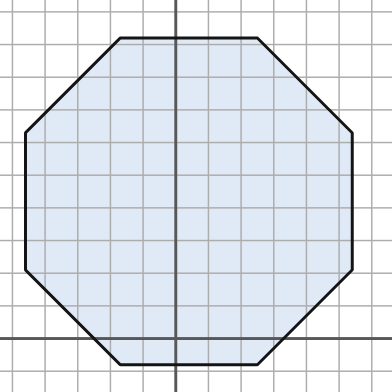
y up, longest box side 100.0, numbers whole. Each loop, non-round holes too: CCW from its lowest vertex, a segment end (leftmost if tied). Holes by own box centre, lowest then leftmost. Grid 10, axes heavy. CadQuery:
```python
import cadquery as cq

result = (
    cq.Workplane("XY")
    .moveTo(-17.0, -8.0)
    .lineTo(25.0, -8.0)
    .lineTo(54.0, 21.0)
    .lineTo(54.0, 63.0)
    .lineTo(25.0, 92.0)
    .lineTo(-17.0, 92.0)
    .lineTo(-46.0, 63.0)
    .lineTo(-46.0, 21.0)
    .close()
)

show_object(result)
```